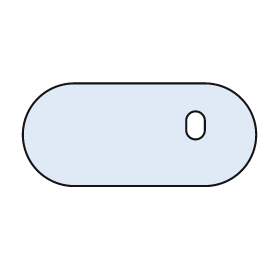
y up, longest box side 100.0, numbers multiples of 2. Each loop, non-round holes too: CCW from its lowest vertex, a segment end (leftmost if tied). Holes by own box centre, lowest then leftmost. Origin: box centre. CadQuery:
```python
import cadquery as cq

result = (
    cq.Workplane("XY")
    .moveTo(-28.0, -22.0)
    .lineTo(28.0, -22.0)
    .threePointArc((50.0, 0.0), (28.0, 22.0))
    .lineTo(-28.0, 22.0)
    .threePointArc((-50.0, 0.0), (-28.0, -22.0))
    .close()
    .moveTo(20.0, 2.0)
    .threePointArc((24.0, -2.0), (28.0, 2.0))
    .lineTo(28.0, 6.0)
    .threePointArc((24.0, 10.0), (20.0, 6.0))
    .close()
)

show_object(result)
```